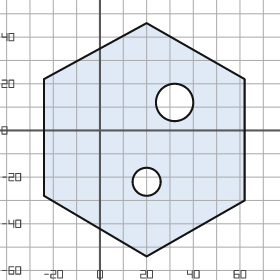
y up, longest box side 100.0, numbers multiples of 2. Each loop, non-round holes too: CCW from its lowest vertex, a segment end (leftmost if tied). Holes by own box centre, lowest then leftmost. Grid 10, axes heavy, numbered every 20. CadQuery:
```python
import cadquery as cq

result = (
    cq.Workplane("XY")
    .moveTo(20.0, -54.0)
    .lineTo(62.0, -30.0)
    .lineTo(62.0, 22.0)
    .lineTo(20.0, 46.0)
    .lineTo(-24.0, 22.0)
    .lineTo(-24.0, -28.0)
    .close()
    .moveTo(20.0, -22.0)
    .circle(6.0)
    .moveTo(32.0, 12.0)
    .circle(8.0)
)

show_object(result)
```